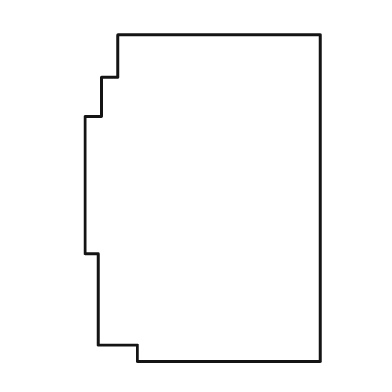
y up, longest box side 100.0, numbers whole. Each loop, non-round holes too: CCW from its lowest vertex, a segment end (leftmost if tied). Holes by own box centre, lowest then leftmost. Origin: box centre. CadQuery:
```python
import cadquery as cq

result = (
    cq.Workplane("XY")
    .moveTo(-20.0, -50.0)
    .lineTo(36.0, -50.0)
    .lineTo(36.0, 50.0)
    .lineTo(-26.0, 50.0)
    .lineTo(-26.0, 37.0)
    .lineTo(-31.0, 37.0)
    .lineTo(-31.0, 25.0)
    .lineTo(-36.0, 25.0)
    .lineTo(-36.0, -17.0)
    .lineTo(-32.0, -17.0)
    .lineTo(-32.0, -45.0)
    .lineTo(-20.0, -45.0)
    .close()
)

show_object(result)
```